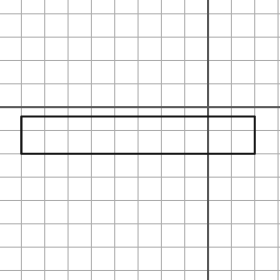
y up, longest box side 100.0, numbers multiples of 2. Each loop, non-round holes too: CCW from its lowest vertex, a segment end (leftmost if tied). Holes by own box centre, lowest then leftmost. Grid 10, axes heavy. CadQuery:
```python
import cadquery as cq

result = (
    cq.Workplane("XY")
    .moveTo(-80.0, -20.0)
    .lineTo(20.0, -20.0)
    .lineTo(20.0, -4.0)
    .lineTo(-80.0, -4.0)
    .close()
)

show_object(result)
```